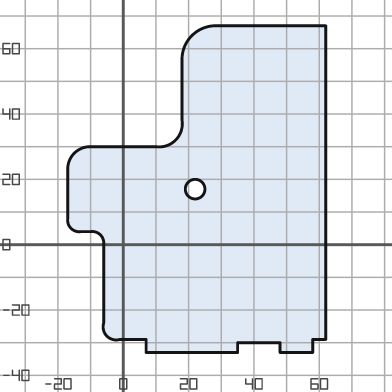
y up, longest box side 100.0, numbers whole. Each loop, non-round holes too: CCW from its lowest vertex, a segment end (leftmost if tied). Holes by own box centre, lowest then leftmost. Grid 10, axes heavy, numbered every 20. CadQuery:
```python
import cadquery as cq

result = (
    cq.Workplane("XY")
    .moveTo(7.0, -33.0)
    .lineTo(35.0, -33.0)
    .lineTo(35.0, -30.0)
    .lineTo(48.0, -30.0)
    .lineTo(48.0, -33.0)
    .lineTo(58.0, -33.0)
    .lineTo(58.0, -29.0)
    .lineTo(62.0, -29.0)
    .lineTo(62.0, 67.0)
    .lineTo(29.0, 67.0)
    .threePointArc((21.0, 64.0), (18.0, 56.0))
    .lineTo(18.0, 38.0)
    .threePointArc((16.0, 32.0), (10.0, 30.0))
    .lineTo(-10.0, 30.0)
    .threePointArc((-15.0, 28.0), (-17.0, 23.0))
    .lineTo(-17.0, 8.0)
    .threePointArc((-16.0, 5.0), (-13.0, 4.0))
    .lineTo(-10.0, 4.0)
    .threePointArc((-7.0, 3.0), (-6.0, 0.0))
    .lineTo(-6.0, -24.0)
    .threePointArc((-5.0, -28.0), (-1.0, -29.0))
    .lineTo(7.0, -29.0)
    .close()
    .moveTo(22.0, 17.0)
    .circle(3.0)
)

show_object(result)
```